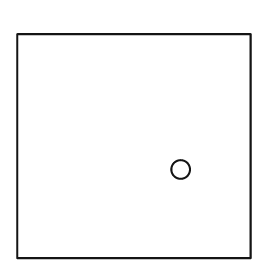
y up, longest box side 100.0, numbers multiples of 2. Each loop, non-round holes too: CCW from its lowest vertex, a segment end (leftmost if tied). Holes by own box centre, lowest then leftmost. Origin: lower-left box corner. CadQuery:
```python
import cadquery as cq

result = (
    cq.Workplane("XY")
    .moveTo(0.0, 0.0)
    .lineTo(100.0, 0.0)
    .lineTo(100.0, 96.0)
    .lineTo(0.0, 96.0)
    .close()
    .moveTo(70.0, 38.0)
    .circle(4.0)
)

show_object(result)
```